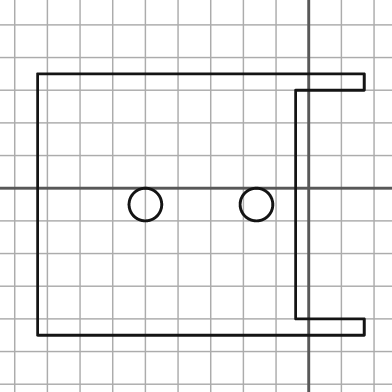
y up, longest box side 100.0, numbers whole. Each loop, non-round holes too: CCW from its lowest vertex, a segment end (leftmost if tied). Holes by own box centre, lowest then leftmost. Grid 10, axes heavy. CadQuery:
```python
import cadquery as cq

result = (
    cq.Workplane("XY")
    .moveTo(-83.0, -45.0)
    .lineTo(17.0, -45.0)
    .lineTo(17.0, -40.0)
    .lineTo(-4.0, -40.0)
    .lineTo(-4.0, 30.0)
    .lineTo(17.0, 30.0)
    .lineTo(17.0, 35.0)
    .lineTo(-83.0, 35.0)
    .close()
    .moveTo(-50.0, -5.0)
    .circle(5.0)
    .moveTo(-16.0, -5.0)
    .circle(5.0)
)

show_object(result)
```